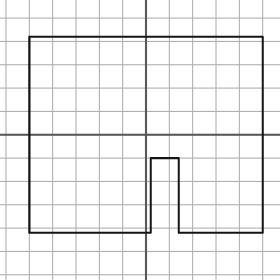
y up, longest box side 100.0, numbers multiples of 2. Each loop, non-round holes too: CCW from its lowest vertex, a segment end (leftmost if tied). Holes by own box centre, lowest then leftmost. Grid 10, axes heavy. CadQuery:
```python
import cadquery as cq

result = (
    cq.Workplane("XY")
    .moveTo(-50.0, -42.0)
    .lineTo(2.0, -42.0)
    .lineTo(2.0, -10.0)
    .lineTo(14.0, -10.0)
    .lineTo(14.0, -42.0)
    .lineTo(50.0, -42.0)
    .lineTo(50.0, 42.0)
    .lineTo(-50.0, 42.0)
    .close()
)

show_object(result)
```